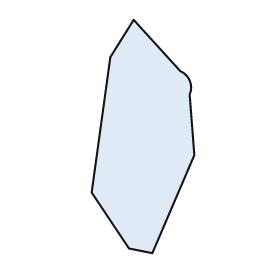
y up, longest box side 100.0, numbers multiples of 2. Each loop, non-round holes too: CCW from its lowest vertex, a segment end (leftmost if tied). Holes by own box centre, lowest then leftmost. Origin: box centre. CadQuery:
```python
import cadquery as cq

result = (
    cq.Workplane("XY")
    .moveTo(4.0, -50.0)
    .lineTo(22.0, -8.0)
    .lineTo(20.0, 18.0)
    .threePointArc((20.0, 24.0), (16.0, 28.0))
    .lineTo(-4.0, 50.0)
    .lineTo(-14.0, 34.0)
    .lineTo(-22.0, -24.0)
    .lineTo(-6.0, -48.0)
    .close()
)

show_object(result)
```